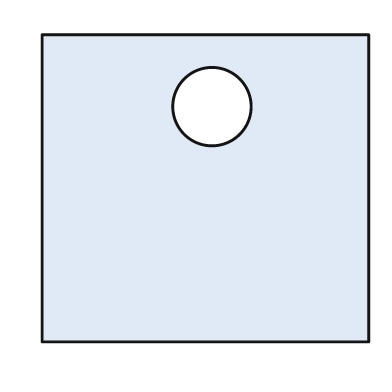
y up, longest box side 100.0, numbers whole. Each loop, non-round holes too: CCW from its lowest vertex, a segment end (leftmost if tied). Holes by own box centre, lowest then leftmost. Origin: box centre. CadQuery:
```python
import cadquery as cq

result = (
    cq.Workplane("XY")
    .moveTo(-50.0, -47.0)
    .lineTo(50.0, -47.0)
    .lineTo(50.0, 47.0)
    .lineTo(-50.0, 47.0)
    .close()
    .moveTo(2.0, 25.0)
    .circle(12.0)
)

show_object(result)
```